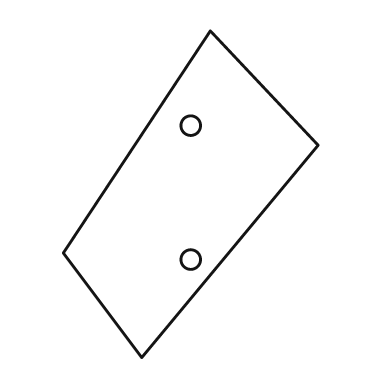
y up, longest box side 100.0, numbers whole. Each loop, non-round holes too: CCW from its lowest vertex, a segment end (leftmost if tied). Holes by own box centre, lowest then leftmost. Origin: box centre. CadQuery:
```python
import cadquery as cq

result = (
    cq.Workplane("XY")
    .moveTo(-15.0, -50.0)
    .lineTo(39.0, 15.0)
    .lineTo(6.0, 50.0)
    .lineTo(-39.0, -18.0)
    .close()
    .moveTo(0.0, -20.0)
    .circle(3.0)
    .moveTo(0.0, 21.0)
    .circle(3.0)
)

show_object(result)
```